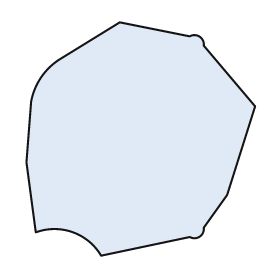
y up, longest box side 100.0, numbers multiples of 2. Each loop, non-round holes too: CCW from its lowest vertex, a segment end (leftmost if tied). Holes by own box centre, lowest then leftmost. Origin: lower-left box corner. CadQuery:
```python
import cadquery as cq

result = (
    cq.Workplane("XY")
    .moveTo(32.0, 0.0)
    .lineTo(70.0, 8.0)
    .threePointArc((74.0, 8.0), (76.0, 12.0))
    .lineTo(86.0, 26.0)
    .lineTo(98.0, 64.0)
    .lineTo(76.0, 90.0)
    .threePointArc((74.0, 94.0), (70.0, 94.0))
    .lineTo(40.0, 100.0)
    .lineTo(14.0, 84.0)
    .threePointArc((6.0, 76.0), (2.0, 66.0))
    .lineTo(0.0, 40.0)
    .lineTo(4.0, 10.0)
    .threePointArc((20.0, 10.0), (32.0, 0.0))
    .close()
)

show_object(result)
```